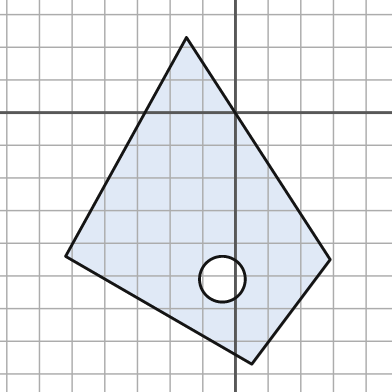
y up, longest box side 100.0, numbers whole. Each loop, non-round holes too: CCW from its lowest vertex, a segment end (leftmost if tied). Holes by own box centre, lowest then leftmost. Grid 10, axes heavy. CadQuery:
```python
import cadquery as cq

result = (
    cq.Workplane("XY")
    .moveTo(5.0, -77.0)
    .lineTo(29.0, -45.0)
    .lineTo(-15.0, 23.0)
    .lineTo(-52.0, -44.0)
    .close()
    .moveTo(-4.0, -51.0)
    .circle(7.0)
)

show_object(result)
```